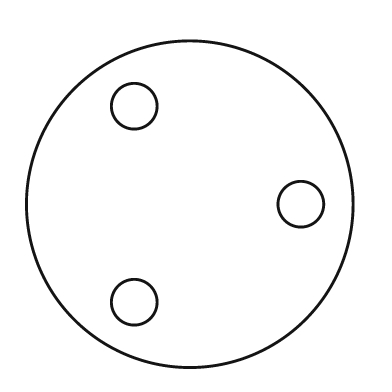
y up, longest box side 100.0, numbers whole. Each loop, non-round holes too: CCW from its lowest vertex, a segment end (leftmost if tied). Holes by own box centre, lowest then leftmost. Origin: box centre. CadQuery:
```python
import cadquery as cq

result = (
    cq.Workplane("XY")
    .moveTo(0.0, 0.0)
    .circle(50.0)
    .moveTo(-17.0, -30.0)
    .circle(7.0)
    .moveTo(34.0, 0.0)
    .circle(7.0)
    .moveTo(-17.0, 30.0)
    .circle(7.0)
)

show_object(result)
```